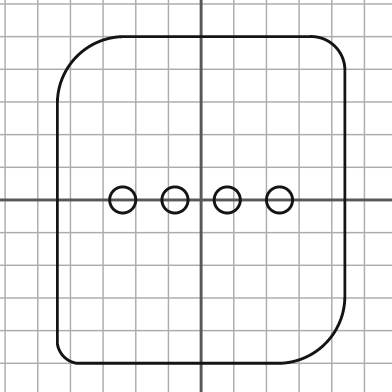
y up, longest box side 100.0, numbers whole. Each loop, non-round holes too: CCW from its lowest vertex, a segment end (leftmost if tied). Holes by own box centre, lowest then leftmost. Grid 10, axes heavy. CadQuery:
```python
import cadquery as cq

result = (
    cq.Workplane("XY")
    .moveTo(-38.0, -50.0)
    .lineTo(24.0, -50.0)
    .threePointArc((38.0, -44.0), (44.0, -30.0))
    .lineTo(44.0, 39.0)
    .threePointArc((41.0, 47.0), (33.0, 50.0))
    .lineTo(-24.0, 50.0)
    .threePointArc((-38.0, 44.0), (-44.0, 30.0))
    .lineTo(-44.0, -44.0)
    .threePointArc((-42.0, -48.0), (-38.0, -50.0))
    .close()
    .moveTo(-24.0, 0.0)
    .circle(4.0)
    .moveTo(-8.0, 0.0)
    .circle(4.0)
    .moveTo(8.0, 0.0)
    .circle(4.0)
    .moveTo(24.0, 0.0)
    .circle(4.0)
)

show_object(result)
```